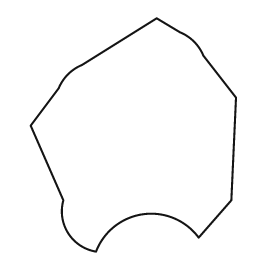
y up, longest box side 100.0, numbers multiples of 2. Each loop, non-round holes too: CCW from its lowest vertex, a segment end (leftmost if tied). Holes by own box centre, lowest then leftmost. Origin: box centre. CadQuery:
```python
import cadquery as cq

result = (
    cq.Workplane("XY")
    .moveTo(-16.0, -50.0)
    .threePointArc((4.0, -34.0), (28.0, -44.0))
    .lineTo(42.0, -28.0)
    .lineTo(44.0, 16.0)
    .lineTo(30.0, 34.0)
    .threePointArc((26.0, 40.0), (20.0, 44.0))
    .lineTo(10.0, 50.0)
    .lineTo(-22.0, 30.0)
    .threePointArc((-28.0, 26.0), (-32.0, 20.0))
    .lineTo(-44.0, 4.0)
    .lineTo(-30.0, -28.0)
    .threePointArc((-28.0, -42.0), (-16.0, -50.0))
    .close()
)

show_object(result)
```